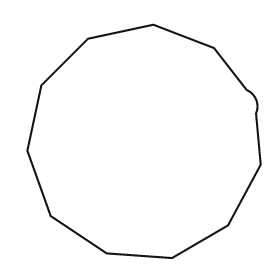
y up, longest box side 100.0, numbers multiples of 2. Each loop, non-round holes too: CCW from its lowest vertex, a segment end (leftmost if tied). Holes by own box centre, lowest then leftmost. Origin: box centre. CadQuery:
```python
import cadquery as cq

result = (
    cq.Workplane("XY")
    .moveTo(12.0, -50.0)
    .lineTo(36.0, -36.0)
    .lineTo(50.0, -10.0)
    .lineTo(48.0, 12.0)
    .threePointArc((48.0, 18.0), (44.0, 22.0))
    .lineTo(30.0, 40.0)
    .lineTo(4.0, 50.0)
    .lineTo(-24.0, 44.0)
    .lineTo(-44.0, 24.0)
    .lineTo(-50.0, -4.0)
    .lineTo(-40.0, -32.0)
    .lineTo(-16.0, -48.0)
    .close()
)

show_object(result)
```